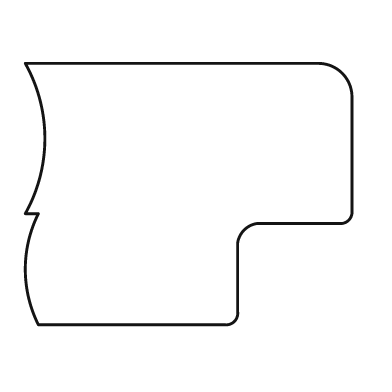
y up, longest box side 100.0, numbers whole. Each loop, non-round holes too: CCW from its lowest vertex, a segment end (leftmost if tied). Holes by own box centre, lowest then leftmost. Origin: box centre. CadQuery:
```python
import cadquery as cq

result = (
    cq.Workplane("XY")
    .moveTo(-46.0, -40.0)
    .lineTo(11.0, -40.0)
    .threePointArc((14.0, -39.0), (15.0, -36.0))
    .lineTo(15.0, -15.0)
    .threePointArc((17.0, -11.0), (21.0, -9.0))
    .lineTo(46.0, -9.0)
    .threePointArc((49.0, -8.0), (50.0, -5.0))
    .lineTo(50.0, 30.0)
    .threePointArc((47.0, 37.0), (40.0, 40.0))
    .lineTo(-50.0, 40.0)
    .threePointArc((-44.0, 17.0), (-50.0, -6.0))
    .lineTo(-46.0, -6.0)
    .threePointArc((-50.0, -23.0), (-46.0, -40.0))
    .close()
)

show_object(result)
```